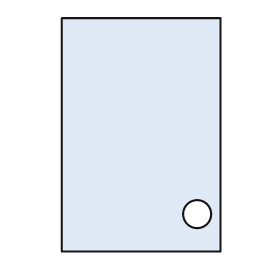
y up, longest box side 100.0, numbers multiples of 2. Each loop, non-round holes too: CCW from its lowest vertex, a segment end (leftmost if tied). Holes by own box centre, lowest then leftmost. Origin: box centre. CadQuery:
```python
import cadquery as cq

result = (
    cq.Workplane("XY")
    .moveTo(-34.0, -50.0)
    .lineTo(34.0, -50.0)
    .lineTo(34.0, 50.0)
    .lineTo(-34.0, 50.0)
    .close()
    .moveTo(24.0, -34.0)
    .circle(6.0)
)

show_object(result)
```